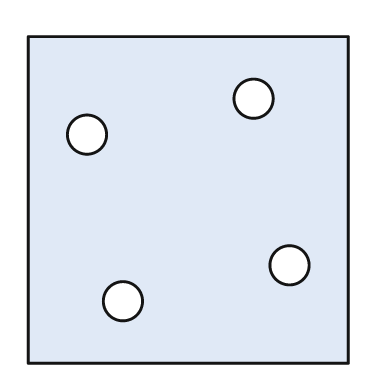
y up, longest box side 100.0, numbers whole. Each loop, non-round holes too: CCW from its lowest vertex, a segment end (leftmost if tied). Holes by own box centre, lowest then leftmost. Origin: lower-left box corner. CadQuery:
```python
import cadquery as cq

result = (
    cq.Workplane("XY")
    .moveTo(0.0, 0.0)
    .lineTo(98.0, 0.0)
    .lineTo(98.0, 100.0)
    .lineTo(0.0, 100.0)
    .close()
    .moveTo(29.0, 19.0)
    .circle(6.0)
    .moveTo(80.0, 30.0)
    .circle(6.0)
    .moveTo(18.0, 70.0)
    .circle(6.0)
    .moveTo(69.0, 81.0)
    .circle(6.0)
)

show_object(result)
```